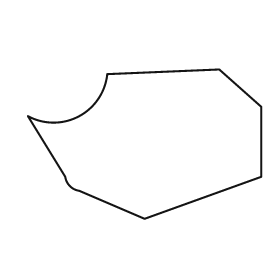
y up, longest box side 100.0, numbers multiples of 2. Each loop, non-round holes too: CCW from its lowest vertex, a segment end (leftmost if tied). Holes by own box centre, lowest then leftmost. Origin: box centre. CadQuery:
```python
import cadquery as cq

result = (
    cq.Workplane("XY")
    .moveTo(0.0, -32.0)
    .lineTo(50.0, -14.0)
    .lineTo(50.0, 16.0)
    .lineTo(32.0, 32.0)
    .lineTo(-16.0, 30.0)
    .threePointArc((-28.0, 12.0), (-50.0, 12.0))
    .lineTo(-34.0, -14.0)
    .threePointArc((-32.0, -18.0), (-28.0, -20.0))
    .close()
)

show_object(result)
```